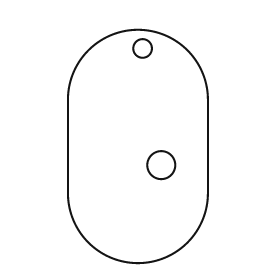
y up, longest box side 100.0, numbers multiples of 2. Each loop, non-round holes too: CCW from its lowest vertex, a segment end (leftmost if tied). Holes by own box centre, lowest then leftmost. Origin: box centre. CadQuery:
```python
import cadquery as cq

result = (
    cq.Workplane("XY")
    .moveTo(-30.0, -20.0)
    .threePointArc((0.0, -50.0), (30.0, -20.0))
    .lineTo(30.0, 20.0)
    .threePointArc((0.0, 50.0), (-30.0, 20.0))
    .close()
    .moveTo(10.0, -8.0)
    .circle(6.0)
    .moveTo(2.0, 42.0)
    .circle(4.0)
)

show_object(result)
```